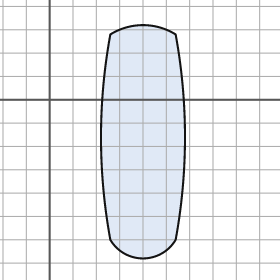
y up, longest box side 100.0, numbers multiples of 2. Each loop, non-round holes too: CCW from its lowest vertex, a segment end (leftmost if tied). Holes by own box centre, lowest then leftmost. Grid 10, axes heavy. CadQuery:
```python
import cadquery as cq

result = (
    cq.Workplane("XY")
    .moveTo(26.0, -60.0)
    .threePointArc((40.0, -68.0), (54.0, -60.0))
    .threePointArc((58.0, -16.0), (54.0, 28.0))
    .threePointArc((40.0, 32.0), (26.0, 28.0))
    .threePointArc((22.0, -16.0), (26.0, -60.0))
    .close()
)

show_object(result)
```